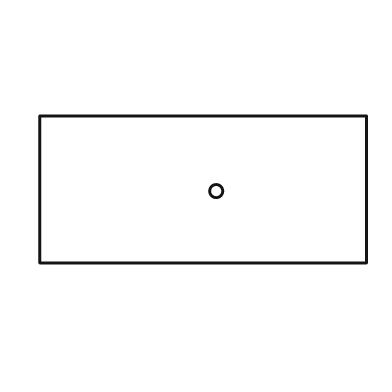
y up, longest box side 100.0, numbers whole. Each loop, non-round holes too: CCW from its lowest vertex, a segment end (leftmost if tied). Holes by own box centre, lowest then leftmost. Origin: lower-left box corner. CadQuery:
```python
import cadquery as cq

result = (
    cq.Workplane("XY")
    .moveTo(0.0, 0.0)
    .lineTo(100.0, 0.0)
    .lineTo(100.0, 45.0)
    .lineTo(0.0, 45.0)
    .close()
    .moveTo(54.0, 22.0)
    .circle(2.0)
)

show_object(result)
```